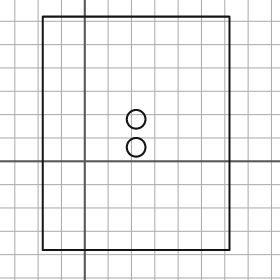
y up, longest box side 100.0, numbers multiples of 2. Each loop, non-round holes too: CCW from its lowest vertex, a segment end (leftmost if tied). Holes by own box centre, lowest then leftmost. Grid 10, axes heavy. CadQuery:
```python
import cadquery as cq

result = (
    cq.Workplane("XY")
    .moveTo(-18.0, -38.0)
    .lineTo(62.0, -38.0)
    .lineTo(62.0, 62.0)
    .lineTo(-18.0, 62.0)
    .close()
    .moveTo(22.0, 6.0)
    .circle(4.0)
    .moveTo(22.0, 18.0)
    .circle(4.0)
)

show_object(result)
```